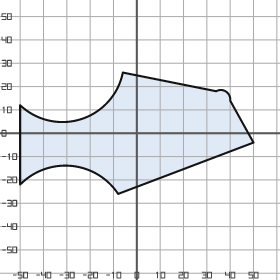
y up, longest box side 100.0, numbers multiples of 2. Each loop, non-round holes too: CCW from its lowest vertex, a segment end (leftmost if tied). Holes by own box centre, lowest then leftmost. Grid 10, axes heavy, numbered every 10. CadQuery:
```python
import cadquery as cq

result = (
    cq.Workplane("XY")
    .moveTo(-8.0, -26.0)
    .lineTo(50.0, -4.0)
    .lineTo(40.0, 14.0)
    .threePointArc((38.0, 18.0), (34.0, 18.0))
    .lineTo(-6.0, 26.0)
    .threePointArc((-24.0, 6.0), (-50.0, 12.0))
    .lineTo(-50.0, -22.0)
    .threePointArc((-28.0, -14.0), (-8.0, -26.0))
    .close()
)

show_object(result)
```